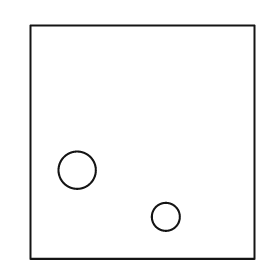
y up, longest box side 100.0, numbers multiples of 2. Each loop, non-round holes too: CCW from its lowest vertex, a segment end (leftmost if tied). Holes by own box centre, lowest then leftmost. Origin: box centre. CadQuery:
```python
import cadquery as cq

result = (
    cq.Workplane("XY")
    .moveTo(-48.0, -50.0)
    .lineTo(48.0, -50.0)
    .lineTo(48.0, 50.0)
    .lineTo(-48.0, 50.0)
    .close()
    .moveTo(10.0, -32.0)
    .circle(6.0)
    .moveTo(-28.0, -12.0)
    .circle(8.0)
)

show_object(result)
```